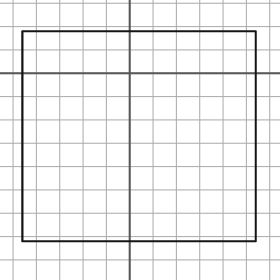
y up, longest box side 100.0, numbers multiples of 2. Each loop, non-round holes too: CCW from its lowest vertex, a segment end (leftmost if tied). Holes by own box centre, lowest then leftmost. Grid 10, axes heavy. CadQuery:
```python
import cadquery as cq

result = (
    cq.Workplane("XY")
    .moveTo(-46.0, -72.0)
    .lineTo(54.0, -72.0)
    .lineTo(54.0, 18.0)
    .lineTo(-46.0, 18.0)
    .close()
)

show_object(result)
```